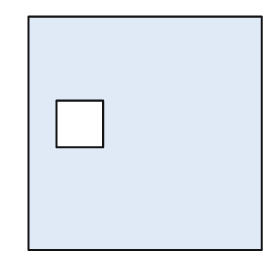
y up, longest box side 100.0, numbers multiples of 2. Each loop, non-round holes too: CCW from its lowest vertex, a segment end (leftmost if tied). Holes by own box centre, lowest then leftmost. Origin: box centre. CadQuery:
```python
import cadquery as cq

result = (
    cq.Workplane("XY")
    .moveTo(-50.0, -50.0)
    .lineTo(50.0, -50.0)
    .lineTo(50.0, 50.0)
    .lineTo(-50.0, 50.0)
    .close()
    .moveTo(-38.0, -6.0)
    .lineTo(-18.0, -6.0)
    .lineTo(-18.0, 14.0)
    .lineTo(-38.0, 14.0)
    .close()
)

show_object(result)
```